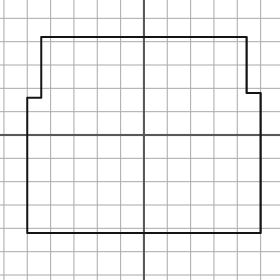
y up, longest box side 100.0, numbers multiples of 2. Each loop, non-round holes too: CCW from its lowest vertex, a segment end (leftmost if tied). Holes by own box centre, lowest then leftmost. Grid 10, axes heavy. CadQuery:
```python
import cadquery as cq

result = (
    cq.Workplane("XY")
    .moveTo(-50.0, -42.0)
    .lineTo(50.0, -42.0)
    .lineTo(50.0, 18.0)
    .lineTo(44.0, 18.0)
    .lineTo(44.0, 42.0)
    .lineTo(-44.0, 42.0)
    .lineTo(-44.0, 16.0)
    .lineTo(-50.0, 16.0)
    .close()
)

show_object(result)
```